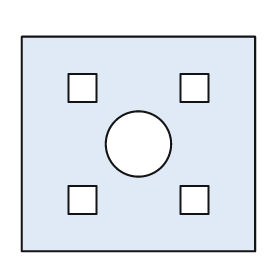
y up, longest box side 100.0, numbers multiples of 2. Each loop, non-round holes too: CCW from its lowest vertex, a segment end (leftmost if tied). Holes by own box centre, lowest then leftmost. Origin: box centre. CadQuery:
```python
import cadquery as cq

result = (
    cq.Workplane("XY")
    .moveTo(-50.0, -46.0)
    .lineTo(50.0, -46.0)
    .lineTo(50.0, 46.0)
    .lineTo(-50.0, 46.0)
    .close()
    .moveTo(-30.0, -30.0)
    .lineTo(-18.0, -30.0)
    .lineTo(-18.0, -18.0)
    .lineTo(-30.0, -18.0)
    .close()
    .moveTo(18.0, -30.0)
    .lineTo(30.0, -30.0)
    .lineTo(30.0, -18.0)
    .lineTo(18.0, -18.0)
    .close()
    .moveTo(0.0, 0.0)
    .circle(14.0)
    .moveTo(-30.0, 18.0)
    .lineTo(-18.0, 18.0)
    .lineTo(-18.0, 30.0)
    .lineTo(-30.0, 30.0)
    .close()
    .moveTo(18.0, 18.0)
    .lineTo(30.0, 18.0)
    .lineTo(30.0, 30.0)
    .lineTo(18.0, 30.0)
    .close()
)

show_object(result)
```